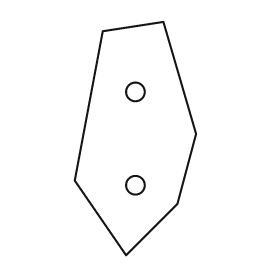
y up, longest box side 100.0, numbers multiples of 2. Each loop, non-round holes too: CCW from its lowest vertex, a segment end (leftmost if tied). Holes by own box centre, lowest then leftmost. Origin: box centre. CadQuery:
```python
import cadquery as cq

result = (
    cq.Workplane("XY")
    .moveTo(-4.0, -50.0)
    .lineTo(18.0, -28.0)
    .lineTo(26.0, 2.0)
    .lineTo(12.0, 50.0)
    .lineTo(-14.0, 46.0)
    .lineTo(-26.0, -18.0)
    .close()
    .moveTo(0.0, -20.0)
    .circle(4.0)
    .moveTo(0.0, 20.0)
    .circle(4.0)
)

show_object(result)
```